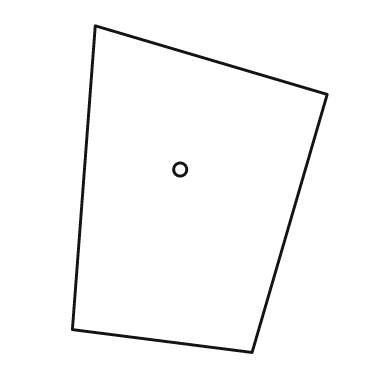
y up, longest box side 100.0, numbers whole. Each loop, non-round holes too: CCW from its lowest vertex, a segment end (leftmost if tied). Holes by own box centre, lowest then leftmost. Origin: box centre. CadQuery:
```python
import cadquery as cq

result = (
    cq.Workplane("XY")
    .moveTo(16.0, -50.0)
    .lineTo(39.0, 29.0)
    .lineTo(-32.0, 50.0)
    .lineTo(-39.0, -43.0)
    .close()
    .moveTo(-6.0, 6.0)
    .circle(2.0)
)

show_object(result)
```